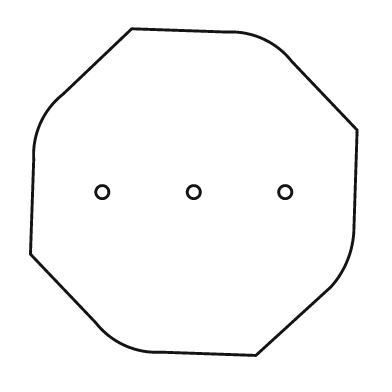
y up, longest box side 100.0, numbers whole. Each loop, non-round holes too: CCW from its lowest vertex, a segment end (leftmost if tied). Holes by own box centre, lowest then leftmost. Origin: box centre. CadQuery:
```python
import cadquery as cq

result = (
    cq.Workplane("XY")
    .moveTo(19.0, -50.0)
    .lineTo(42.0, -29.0)
    .threePointArc((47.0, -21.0), (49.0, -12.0))
    .lineTo(50.0, 19.0)
    .lineTo(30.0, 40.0)
    .threePointArc((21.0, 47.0), (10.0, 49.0))
    .lineTo(-19.0, 50.0)
    .lineTo(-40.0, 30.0)
    .threePointArc((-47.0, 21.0), (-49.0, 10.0))
    .lineTo(-50.0, -19.0)
    .lineTo(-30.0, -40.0)
    .threePointArc((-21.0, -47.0), (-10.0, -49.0))
    .close()
    .moveTo(-28.0, 0.0)
    .circle(2.0)
    .moveTo(0.0, 0.0)
    .circle(2.0)
    .moveTo(28.0, 0.0)
    .circle(2.0)
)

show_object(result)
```